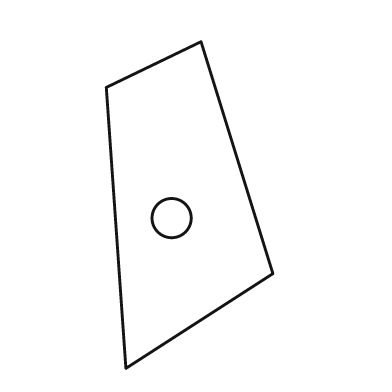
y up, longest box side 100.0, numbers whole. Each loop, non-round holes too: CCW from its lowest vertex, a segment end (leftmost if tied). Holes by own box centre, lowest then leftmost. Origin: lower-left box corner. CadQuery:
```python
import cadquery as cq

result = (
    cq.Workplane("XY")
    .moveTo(6.0, 0.0)
    .lineTo(51.0, 29.0)
    .lineTo(29.0, 100.0)
    .lineTo(0.0, 86.0)
    .close()
    .moveTo(20.0, 46.0)
    .circle(6.0)
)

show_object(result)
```